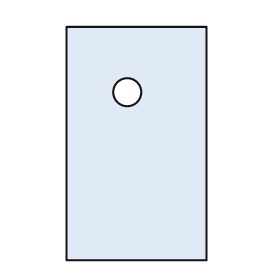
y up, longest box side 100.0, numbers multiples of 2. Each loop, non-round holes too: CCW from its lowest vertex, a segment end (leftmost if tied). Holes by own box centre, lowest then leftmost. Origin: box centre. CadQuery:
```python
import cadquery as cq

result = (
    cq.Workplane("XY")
    .moveTo(-30.0, -50.0)
    .lineTo(30.0, -50.0)
    .lineTo(30.0, 50.0)
    .lineTo(-30.0, 50.0)
    .close()
    .moveTo(-4.0, 22.0)
    .circle(6.0)
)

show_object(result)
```